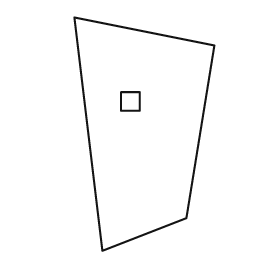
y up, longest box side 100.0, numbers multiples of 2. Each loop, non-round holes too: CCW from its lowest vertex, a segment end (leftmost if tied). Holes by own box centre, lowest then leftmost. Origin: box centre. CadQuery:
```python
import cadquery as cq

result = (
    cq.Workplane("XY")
    .moveTo(-18.0, -50.0)
    .lineTo(18.0, -36.0)
    .lineTo(30.0, 38.0)
    .lineTo(-30.0, 50.0)
    .close()
    .moveTo(-10.0, 10.0)
    .lineTo(-2.0, 10.0)
    .lineTo(-2.0, 18.0)
    .lineTo(-10.0, 18.0)
    .close()
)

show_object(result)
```